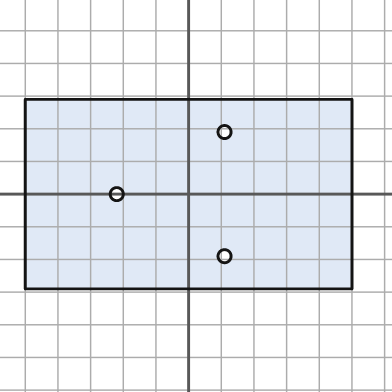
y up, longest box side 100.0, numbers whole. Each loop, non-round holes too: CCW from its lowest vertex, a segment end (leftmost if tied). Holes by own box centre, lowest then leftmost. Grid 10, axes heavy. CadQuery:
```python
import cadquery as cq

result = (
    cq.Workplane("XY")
    .moveTo(-50.0, -29.0)
    .lineTo(50.0, -29.0)
    .lineTo(50.0, 29.0)
    .lineTo(-50.0, 29.0)
    .close()
    .moveTo(11.0, -19.0)
    .circle(2.0)
    .moveTo(-22.0, 0.0)
    .circle(2.0)
    .moveTo(11.0, 19.0)
    .circle(2.0)
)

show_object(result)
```